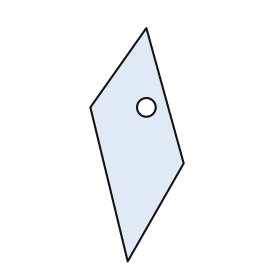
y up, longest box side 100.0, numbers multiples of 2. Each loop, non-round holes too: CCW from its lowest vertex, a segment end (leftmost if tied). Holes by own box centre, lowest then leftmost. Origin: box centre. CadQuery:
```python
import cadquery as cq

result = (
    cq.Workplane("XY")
    .moveTo(-4.0, -50.0)
    .lineTo(20.0, -8.0)
    .lineTo(4.0, 50.0)
    .lineTo(-20.0, 16.0)
    .close()
    .moveTo(4.0, 16.0)
    .circle(4.0)
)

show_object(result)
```